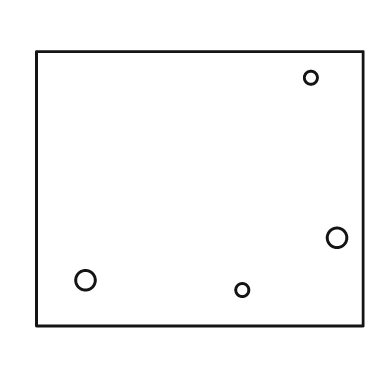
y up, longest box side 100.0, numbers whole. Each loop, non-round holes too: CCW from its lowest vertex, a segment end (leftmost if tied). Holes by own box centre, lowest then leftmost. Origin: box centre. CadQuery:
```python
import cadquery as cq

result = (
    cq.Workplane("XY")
    .moveTo(-50.0, -42.0)
    .lineTo(50.0, -42.0)
    .lineTo(50.0, 42.0)
    .lineTo(-50.0, 42.0)
    .close()
    .moveTo(13.0, -31.0)
    .circle(2.0)
    .moveTo(-35.0, -28.0)
    .circle(3.0)
    .moveTo(42.0, -15.0)
    .circle(3.0)
    .moveTo(34.0, 34.0)
    .circle(2.0)
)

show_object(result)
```